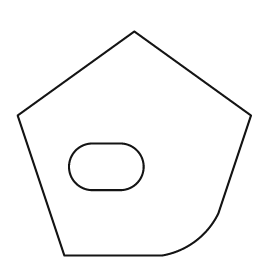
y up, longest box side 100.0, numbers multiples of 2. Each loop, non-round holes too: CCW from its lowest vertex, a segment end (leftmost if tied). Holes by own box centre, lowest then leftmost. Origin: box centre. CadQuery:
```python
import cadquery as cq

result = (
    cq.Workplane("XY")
    .moveTo(-30.0, -48.0)
    .lineTo(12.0, -48.0)
    .threePointArc((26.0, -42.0), (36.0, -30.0))
    .lineTo(50.0, 12.0)
    .lineTo(0.0, 48.0)
    .lineTo(-50.0, 12.0)
    .close()
    .moveTo(-18.0, -20.0)
    .lineTo(-6.0, -20.0)
    .threePointArc((4.0, -10.0), (-6.0, 0.0))
    .lineTo(-18.0, 0.0)
    .threePointArc((-28.0, -10.0), (-18.0, -20.0))
    .close()
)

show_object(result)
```